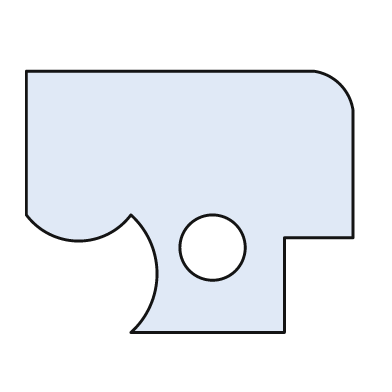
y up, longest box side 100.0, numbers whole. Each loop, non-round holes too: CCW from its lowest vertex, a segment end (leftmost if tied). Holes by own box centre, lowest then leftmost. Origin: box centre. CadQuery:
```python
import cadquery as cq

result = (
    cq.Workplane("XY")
    .moveTo(-18.0, -40.0)
    .lineTo(29.0, -40.0)
    .lineTo(29.0, -11.0)
    .lineTo(50.0, -11.0)
    .lineTo(50.0, 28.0)
    .threePointArc((46.0, 36.0), (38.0, 40.0))
    .lineTo(-50.0, 40.0)
    .lineTo(-50.0, -4.0)
    .threePointArc((-34.0, -12.0), (-18.0, -4.0))
    .threePointArc((-10.0, -22.0), (-18.0, -40.0))
    .close()
    .moveTo(7.0, -14.0)
    .circle(10.0)
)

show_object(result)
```